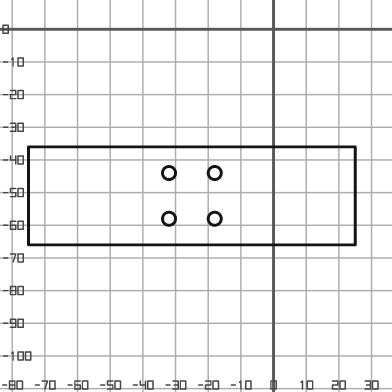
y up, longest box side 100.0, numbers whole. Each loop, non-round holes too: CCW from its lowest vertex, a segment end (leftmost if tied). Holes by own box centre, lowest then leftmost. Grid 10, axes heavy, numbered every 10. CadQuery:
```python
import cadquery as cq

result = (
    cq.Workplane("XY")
    .moveTo(-75.0, -66.0)
    .lineTo(25.0, -66.0)
    .lineTo(25.0, -36.0)
    .lineTo(-75.0, -36.0)
    .close()
    .moveTo(-32.0, -58.0)
    .circle(2.0)
    .moveTo(-18.0, -58.0)
    .circle(2.0)
    .moveTo(-32.0, -44.0)
    .circle(2.0)
    .moveTo(-18.0, -44.0)
    .circle(2.0)
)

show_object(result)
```